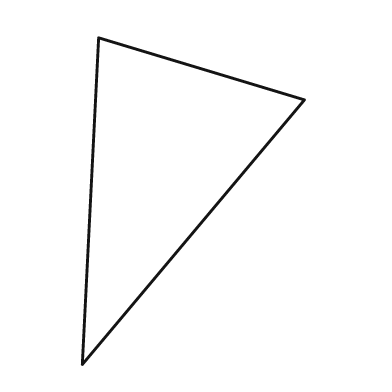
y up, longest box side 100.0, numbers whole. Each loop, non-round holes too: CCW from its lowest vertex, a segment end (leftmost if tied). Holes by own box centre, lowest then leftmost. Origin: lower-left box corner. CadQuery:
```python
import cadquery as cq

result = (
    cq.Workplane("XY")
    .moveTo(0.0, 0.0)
    .lineTo(68.0, 81.0)
    .lineTo(5.0, 100.0)
    .close()
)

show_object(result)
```